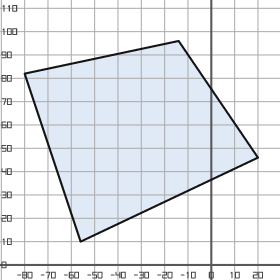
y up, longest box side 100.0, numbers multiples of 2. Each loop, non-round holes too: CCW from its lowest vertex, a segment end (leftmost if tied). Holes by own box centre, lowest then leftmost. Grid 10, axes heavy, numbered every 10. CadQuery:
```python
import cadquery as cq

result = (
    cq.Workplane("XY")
    .moveTo(-56.0, 10.0)
    .lineTo(20.0, 46.0)
    .lineTo(-14.0, 96.0)
    .lineTo(-80.0, 82.0)
    .close()
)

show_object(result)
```